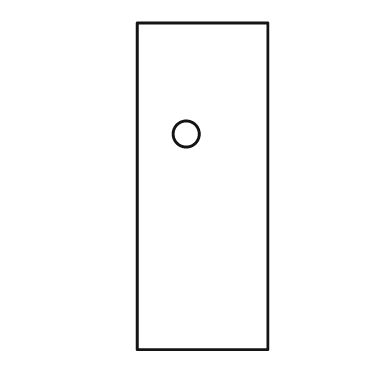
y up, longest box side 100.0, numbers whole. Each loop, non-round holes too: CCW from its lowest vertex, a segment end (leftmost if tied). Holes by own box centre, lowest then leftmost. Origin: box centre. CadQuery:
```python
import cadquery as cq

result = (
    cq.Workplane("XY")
    .moveTo(-20.0, -50.0)
    .lineTo(20.0, -50.0)
    .lineTo(20.0, 50.0)
    .lineTo(-20.0, 50.0)
    .close()
    .moveTo(-5.0, 16.0)
    .circle(4.0)
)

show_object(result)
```